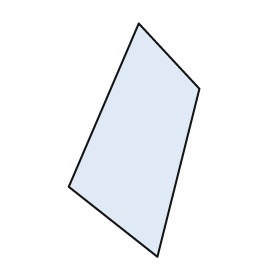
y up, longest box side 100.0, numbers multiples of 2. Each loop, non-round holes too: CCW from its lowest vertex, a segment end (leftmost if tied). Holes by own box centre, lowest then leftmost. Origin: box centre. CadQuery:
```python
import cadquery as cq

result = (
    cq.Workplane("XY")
    .moveTo(10.0, -50.0)
    .lineTo(28.0, 22.0)
    .lineTo(2.0, 50.0)
    .lineTo(-28.0, -20.0)
    .close()
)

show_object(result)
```